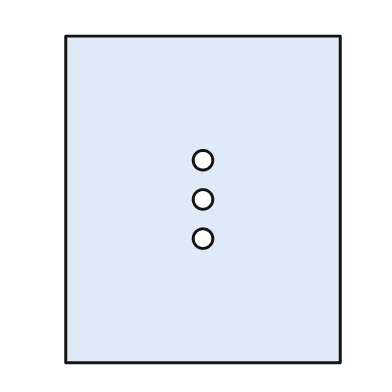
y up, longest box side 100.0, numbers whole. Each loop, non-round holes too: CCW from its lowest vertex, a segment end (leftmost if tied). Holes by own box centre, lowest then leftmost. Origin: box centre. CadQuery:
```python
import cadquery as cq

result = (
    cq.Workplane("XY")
    .moveTo(-42.0, -50.0)
    .lineTo(42.0, -50.0)
    .lineTo(42.0, 50.0)
    .lineTo(-42.0, 50.0)
    .close()
    .moveTo(0.0, -12.0)
    .circle(3.0)
    .moveTo(0.0, 0.0)
    .circle(3.0)
    .moveTo(0.0, 12.0)
    .circle(3.0)
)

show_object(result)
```